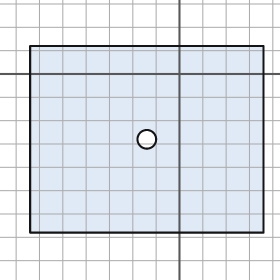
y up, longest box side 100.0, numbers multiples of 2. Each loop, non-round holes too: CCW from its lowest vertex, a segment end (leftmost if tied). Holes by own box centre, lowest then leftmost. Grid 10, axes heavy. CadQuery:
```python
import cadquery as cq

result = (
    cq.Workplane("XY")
    .moveTo(-64.0, -68.0)
    .lineTo(36.0, -68.0)
    .lineTo(36.0, 12.0)
    .lineTo(-64.0, 12.0)
    .close()
    .moveTo(-14.0, -28.0)
    .circle(4.0)
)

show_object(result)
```